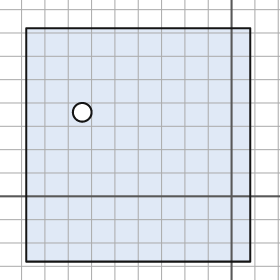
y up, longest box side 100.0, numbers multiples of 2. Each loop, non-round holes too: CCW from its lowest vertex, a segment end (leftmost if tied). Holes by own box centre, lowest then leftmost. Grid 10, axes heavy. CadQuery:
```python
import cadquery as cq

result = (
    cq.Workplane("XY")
    .moveTo(-88.0, -28.0)
    .lineTo(8.0, -28.0)
    .lineTo(8.0, 72.0)
    .lineTo(-88.0, 72.0)
    .close()
    .moveTo(-64.0, 36.0)
    .circle(4.0)
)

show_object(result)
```